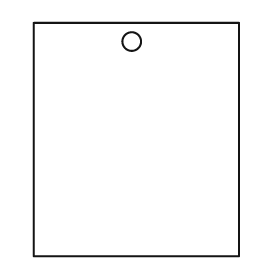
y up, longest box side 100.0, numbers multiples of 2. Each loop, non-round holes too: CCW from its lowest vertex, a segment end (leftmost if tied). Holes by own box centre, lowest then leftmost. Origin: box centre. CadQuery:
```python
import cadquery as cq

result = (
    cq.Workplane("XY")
    .moveTo(-44.0, -50.0)
    .lineTo(44.0, -50.0)
    .lineTo(44.0, 50.0)
    .lineTo(-44.0, 50.0)
    .close()
    .moveTo(-2.0, 42.0)
    .circle(4.0)
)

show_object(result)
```